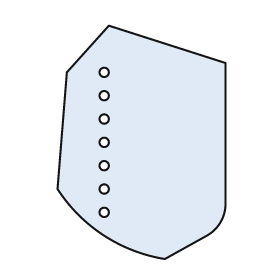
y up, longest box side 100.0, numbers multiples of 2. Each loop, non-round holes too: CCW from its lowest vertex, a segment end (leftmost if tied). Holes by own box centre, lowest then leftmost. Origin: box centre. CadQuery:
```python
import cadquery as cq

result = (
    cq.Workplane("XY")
    .moveTo(10.0, -50.0)
    .lineTo(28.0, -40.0)
    .threePointArc((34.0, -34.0), (36.0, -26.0))
    .lineTo(36.0, 34.0)
    .lineTo(-14.0, 50.0)
    .lineTo(-32.0, 30.0)
    .lineTo(-36.0, -20.0)
    .threePointArc((-16.0, -40.0), (10.0, -50.0))
    .close()
    .moveTo(-16.0, -30.0)
    .circle(2.0)
    .moveTo(-16.0, -20.0)
    .circle(2.0)
    .moveTo(-16.0, -10.0)
    .circle(2.0)
    .moveTo(-16.0, 0.0)
    .circle(2.0)
    .moveTo(-16.0, 10.0)
    .circle(2.0)
    .moveTo(-16.0, 20.0)
    .circle(2.0)
    .moveTo(-16.0, 30.0)
    .circle(2.0)
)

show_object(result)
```